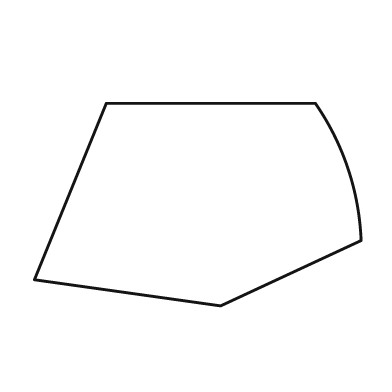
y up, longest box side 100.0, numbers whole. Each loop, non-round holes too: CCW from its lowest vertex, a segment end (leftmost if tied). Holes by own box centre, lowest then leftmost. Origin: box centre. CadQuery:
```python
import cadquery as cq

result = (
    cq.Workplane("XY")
    .moveTo(7.0, -31.0)
    .lineTo(50.0, -11.0)
    .threePointArc((46.0, 11.0), (36.0, 31.0))
    .lineTo(-28.0, 31.0)
    .lineTo(-50.0, -23.0)
    .close()
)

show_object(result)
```